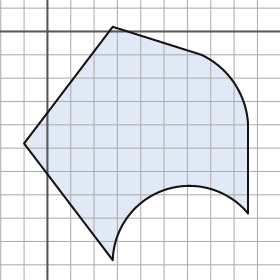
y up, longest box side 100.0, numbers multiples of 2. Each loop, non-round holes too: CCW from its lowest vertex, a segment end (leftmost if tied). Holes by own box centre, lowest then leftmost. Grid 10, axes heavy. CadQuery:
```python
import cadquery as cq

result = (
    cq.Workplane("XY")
    .moveTo(28.0, -98.0)
    .threePointArc((50.0, -68.0), (86.0, -78.0))
    .lineTo(86.0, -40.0)
    .threePointArc((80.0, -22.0), (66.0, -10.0))
    .lineTo(28.0, 2.0)
    .lineTo(-10.0, -48.0)
    .close()
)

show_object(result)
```